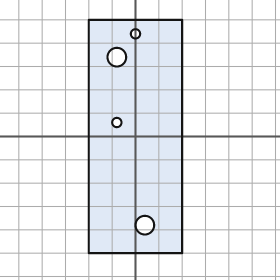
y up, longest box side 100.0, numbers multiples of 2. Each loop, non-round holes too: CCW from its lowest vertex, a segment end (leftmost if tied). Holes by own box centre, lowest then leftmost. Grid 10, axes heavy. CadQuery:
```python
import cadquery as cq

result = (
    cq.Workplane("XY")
    .moveTo(-20.0, -50.0)
    .lineTo(20.0, -50.0)
    .lineTo(20.0, 50.0)
    .lineTo(-20.0, 50.0)
    .close()
    .moveTo(4.0, -38.0)
    .circle(4.0)
    .moveTo(-8.0, 6.0)
    .circle(2.0)
    .moveTo(-8.0, 34.0)
    .circle(4.0)
    .moveTo(0.0, 44.0)
    .circle(2.0)
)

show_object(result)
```